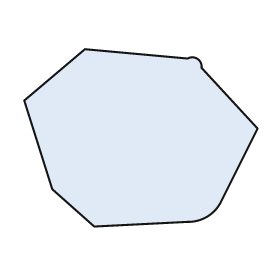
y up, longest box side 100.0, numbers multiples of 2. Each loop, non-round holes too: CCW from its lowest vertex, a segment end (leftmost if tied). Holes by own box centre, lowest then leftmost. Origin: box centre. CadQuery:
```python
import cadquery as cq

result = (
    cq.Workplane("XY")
    .moveTo(-20.0, -38.0)
    .lineTo(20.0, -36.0)
    .threePointArc((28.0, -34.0), (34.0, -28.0))
    .lineTo(50.0, 4.0)
    .lineTo(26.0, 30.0)
    .threePointArc((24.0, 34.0), (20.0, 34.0))
    .lineTo(-24.0, 38.0)
    .lineTo(-50.0, 16.0)
    .lineTo(-38.0, -22.0)
    .close()
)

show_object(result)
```